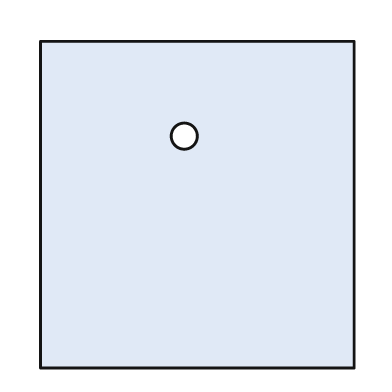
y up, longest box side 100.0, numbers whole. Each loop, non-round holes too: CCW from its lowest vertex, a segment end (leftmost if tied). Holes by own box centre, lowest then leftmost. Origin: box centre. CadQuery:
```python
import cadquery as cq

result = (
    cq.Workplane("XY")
    .moveTo(-48.0, -50.0)
    .lineTo(48.0, -50.0)
    .lineTo(48.0, 50.0)
    .lineTo(-48.0, 50.0)
    .close()
    .moveTo(-4.0, 21.0)
    .circle(4.0)
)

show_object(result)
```